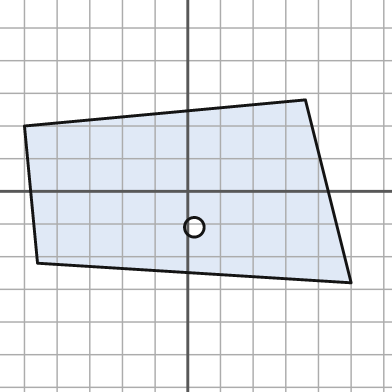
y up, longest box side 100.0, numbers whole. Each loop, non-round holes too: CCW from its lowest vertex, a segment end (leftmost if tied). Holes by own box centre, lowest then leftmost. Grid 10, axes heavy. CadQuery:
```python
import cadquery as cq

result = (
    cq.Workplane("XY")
    .moveTo(50.0, -28.0)
    .lineTo(36.0, 28.0)
    .lineTo(-50.0, 20.0)
    .lineTo(-46.0, -22.0)
    .close()
    .moveTo(2.0, -11.0)
    .circle(3.0)
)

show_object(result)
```